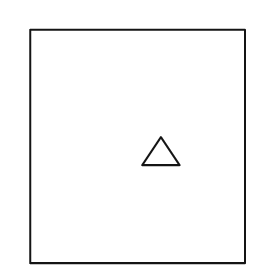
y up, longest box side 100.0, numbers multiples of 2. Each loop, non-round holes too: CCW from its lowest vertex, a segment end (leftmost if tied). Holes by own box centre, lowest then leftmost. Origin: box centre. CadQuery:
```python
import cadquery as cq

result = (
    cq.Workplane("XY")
    .moveTo(-46.0, -50.0)
    .lineTo(46.0, -50.0)
    .lineTo(46.0, 50.0)
    .lineTo(-46.0, 50.0)
    .close()
    .moveTo(2.0, -8.0)
    .lineTo(18.0, -8.0)
    .lineTo(10.0, 4.0)
    .close()
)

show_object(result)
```